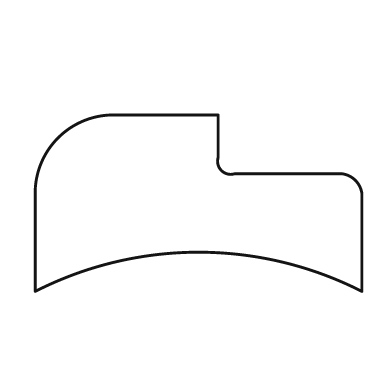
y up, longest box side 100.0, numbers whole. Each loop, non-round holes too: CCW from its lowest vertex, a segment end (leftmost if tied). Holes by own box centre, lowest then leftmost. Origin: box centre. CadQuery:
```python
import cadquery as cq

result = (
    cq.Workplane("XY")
    .moveTo(-50.0, -27.0)
    .threePointArc((0.0, -15.0), (50.0, -27.0))
    .lineTo(50.0, 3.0)
    .threePointArc((48.0, 7.0), (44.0, 9.0))
    .lineTo(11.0, 9.0)
    .threePointArc((7.0, 10.0), (6.0, 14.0))
    .lineTo(6.0, 27.0)
    .lineTo(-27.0, 27.0)
    .threePointArc((-43.0, 20.0), (-50.0, 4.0))
    .close()
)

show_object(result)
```